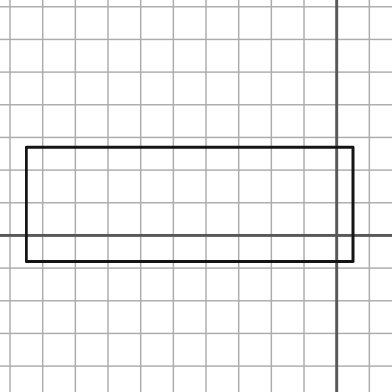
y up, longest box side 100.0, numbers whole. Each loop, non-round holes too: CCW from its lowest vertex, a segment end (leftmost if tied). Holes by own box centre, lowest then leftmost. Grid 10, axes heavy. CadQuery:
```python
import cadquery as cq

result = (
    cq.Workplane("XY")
    .moveTo(-95.0, -8.0)
    .lineTo(5.0, -8.0)
    .lineTo(5.0, 27.0)
    .lineTo(-95.0, 27.0)
    .close()
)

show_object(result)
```